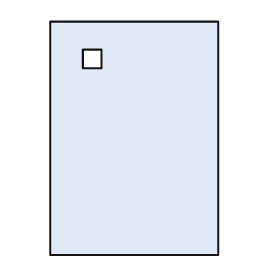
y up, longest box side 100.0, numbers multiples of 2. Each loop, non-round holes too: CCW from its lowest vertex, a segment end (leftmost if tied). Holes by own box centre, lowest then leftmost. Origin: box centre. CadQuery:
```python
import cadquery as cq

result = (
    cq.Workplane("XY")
    .moveTo(-36.0, -50.0)
    .lineTo(36.0, -50.0)
    .lineTo(36.0, 50.0)
    .lineTo(-36.0, 50.0)
    .close()
    .moveTo(-22.0, 30.0)
    .lineTo(-14.0, 30.0)
    .lineTo(-14.0, 38.0)
    .lineTo(-22.0, 38.0)
    .close()
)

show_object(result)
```